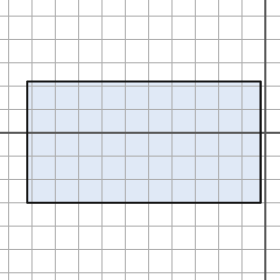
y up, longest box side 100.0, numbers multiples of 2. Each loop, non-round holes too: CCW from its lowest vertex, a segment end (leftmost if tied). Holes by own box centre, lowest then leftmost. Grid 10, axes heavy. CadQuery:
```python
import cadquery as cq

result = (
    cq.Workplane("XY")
    .moveTo(-102.0, -30.0)
    .lineTo(-2.0, -30.0)
    .lineTo(-2.0, 22.0)
    .lineTo(-102.0, 22.0)
    .close()
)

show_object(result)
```